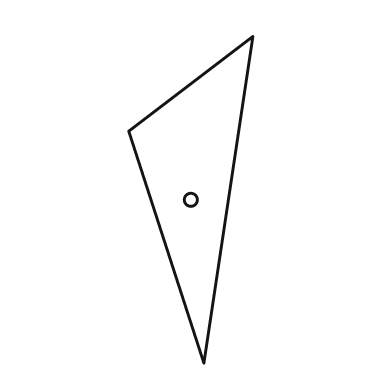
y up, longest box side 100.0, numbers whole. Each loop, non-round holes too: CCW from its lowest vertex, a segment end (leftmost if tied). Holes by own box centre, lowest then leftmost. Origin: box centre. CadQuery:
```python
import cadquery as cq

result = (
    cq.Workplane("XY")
    .moveTo(4.0, -50.0)
    .lineTo(19.0, 50.0)
    .lineTo(-19.0, 21.0)
    .close()
    .moveTo(0.0, 0.0)
    .circle(2.0)
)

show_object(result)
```